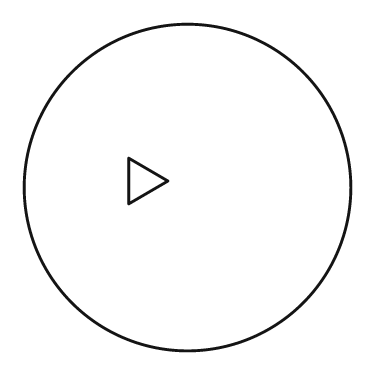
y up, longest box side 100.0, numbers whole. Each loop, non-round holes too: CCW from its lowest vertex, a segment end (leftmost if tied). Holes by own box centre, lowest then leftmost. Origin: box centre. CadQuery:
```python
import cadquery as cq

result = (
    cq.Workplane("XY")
    .moveTo(0.0, 0.0)
    .circle(50.0)
    .moveTo(-18.0, -5.0)
    .lineTo(-6.0, 2.0)
    .lineTo(-18.0, 9.0)
    .close()
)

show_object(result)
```